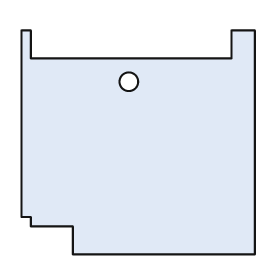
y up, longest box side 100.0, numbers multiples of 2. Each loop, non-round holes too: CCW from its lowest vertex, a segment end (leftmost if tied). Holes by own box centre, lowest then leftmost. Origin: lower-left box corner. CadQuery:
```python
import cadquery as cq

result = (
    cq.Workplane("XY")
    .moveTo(22.0, 0.0)
    .lineTo(100.0, 0.0)
    .lineTo(100.0, 96.0)
    .lineTo(90.0, 96.0)
    .lineTo(90.0, 84.0)
    .lineTo(4.0, 84.0)
    .lineTo(4.0, 96.0)
    .lineTo(0.0, 96.0)
    .lineTo(0.0, 16.0)
    .lineTo(4.0, 16.0)
    .lineTo(4.0, 12.0)
    .lineTo(22.0, 12.0)
    .close()
    .moveTo(46.0, 74.0)
    .circle(4.0)
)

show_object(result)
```